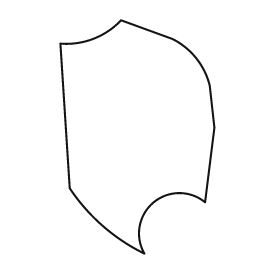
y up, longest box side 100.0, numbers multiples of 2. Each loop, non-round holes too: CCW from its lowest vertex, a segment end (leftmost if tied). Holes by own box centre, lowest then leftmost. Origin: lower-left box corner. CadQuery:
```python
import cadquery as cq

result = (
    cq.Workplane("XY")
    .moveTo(36.0, 0.0)
    .threePointArc((40.0, 22.0), (62.0, 22.0))
    .lineTo(66.0, 54.0)
    .lineTo(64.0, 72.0)
    .threePointArc((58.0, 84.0), (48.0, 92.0))
    .lineTo(26.0, 100.0)
    .threePointArc((14.0, 92.0), (0.0, 90.0))
    .lineTo(4.0, 28.0)
    .threePointArc((18.0, 12.0), (36.0, 0.0))
    .close()
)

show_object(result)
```